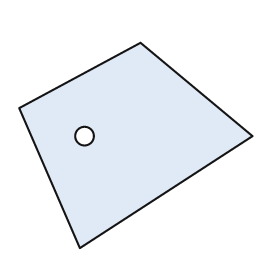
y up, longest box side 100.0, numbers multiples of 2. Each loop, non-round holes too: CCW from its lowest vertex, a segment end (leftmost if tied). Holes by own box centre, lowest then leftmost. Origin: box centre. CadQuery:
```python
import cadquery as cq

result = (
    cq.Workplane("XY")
    .moveTo(-24.0, -44.0)
    .lineTo(50.0, 4.0)
    .lineTo(2.0, 44.0)
    .lineTo(-50.0, 16.0)
    .close()
    .moveTo(-22.0, 4.0)
    .circle(4.0)
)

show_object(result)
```